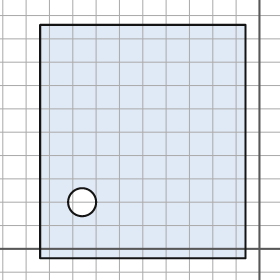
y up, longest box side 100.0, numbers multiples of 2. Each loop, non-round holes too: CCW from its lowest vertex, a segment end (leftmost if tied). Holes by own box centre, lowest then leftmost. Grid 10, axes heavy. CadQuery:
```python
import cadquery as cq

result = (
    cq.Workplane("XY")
    .moveTo(-94.0, -4.0)
    .lineTo(-6.0, -4.0)
    .lineTo(-6.0, 96.0)
    .lineTo(-94.0, 96.0)
    .close()
    .moveTo(-76.0, 20.0)
    .circle(6.0)
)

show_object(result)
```